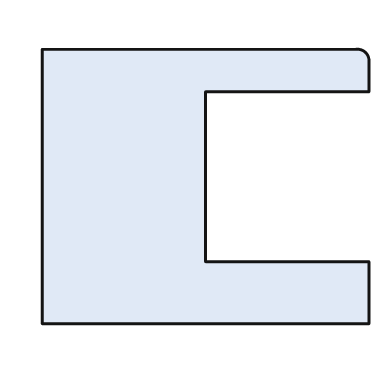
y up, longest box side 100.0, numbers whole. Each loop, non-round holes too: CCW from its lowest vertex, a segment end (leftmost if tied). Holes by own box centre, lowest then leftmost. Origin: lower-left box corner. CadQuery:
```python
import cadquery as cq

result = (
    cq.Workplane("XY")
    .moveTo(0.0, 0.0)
    .lineTo(100.0, 0.0)
    .lineTo(100.0, 19.0)
    .lineTo(50.0, 19.0)
    .lineTo(50.0, 71.0)
    .lineTo(100.0, 71.0)
    .lineTo(100.0, 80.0)
    .threePointArc((99.0, 83.0), (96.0, 84.0))
    .lineTo(0.0, 84.0)
    .close()
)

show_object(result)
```